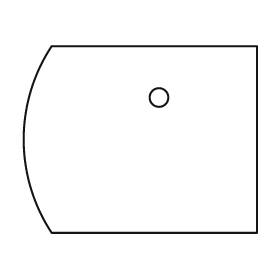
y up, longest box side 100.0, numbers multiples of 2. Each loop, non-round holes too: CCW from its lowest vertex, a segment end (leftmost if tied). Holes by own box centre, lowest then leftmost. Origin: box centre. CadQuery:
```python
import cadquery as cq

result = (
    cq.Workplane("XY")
    .moveTo(-38.0, -40.0)
    .lineTo(50.0, -40.0)
    .lineTo(50.0, 40.0)
    .lineTo(-38.0, 40.0)
    .threePointArc((-50.0, 0.0), (-38.0, -40.0))
    .close()
    .moveTo(8.0, 18.0)
    .circle(4.0)
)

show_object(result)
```